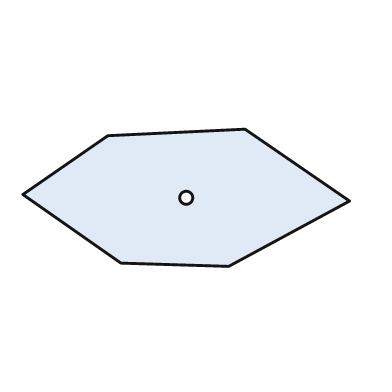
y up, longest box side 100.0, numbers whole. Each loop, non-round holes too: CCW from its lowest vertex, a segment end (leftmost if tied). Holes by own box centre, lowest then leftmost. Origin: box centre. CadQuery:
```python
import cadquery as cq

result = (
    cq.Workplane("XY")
    .moveTo(13.0, -21.0)
    .lineTo(50.0, -1.0)
    .lineTo(18.0, 21.0)
    .lineTo(-24.0, 19.0)
    .lineTo(-50.0, 1.0)
    .lineTo(-20.0, -20.0)
    .close()
    .moveTo(0.0, 0.0)
    .circle(2.0)
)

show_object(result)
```